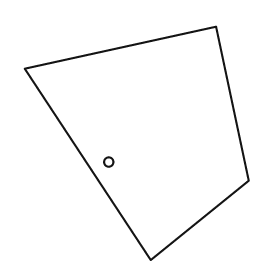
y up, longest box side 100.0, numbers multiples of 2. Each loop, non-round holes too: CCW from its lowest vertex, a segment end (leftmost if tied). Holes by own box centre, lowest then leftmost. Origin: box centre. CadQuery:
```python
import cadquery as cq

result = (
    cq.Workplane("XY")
    .moveTo(6.0, -50.0)
    .lineTo(48.0, -16.0)
    .lineTo(34.0, 50.0)
    .lineTo(-48.0, 32.0)
    .close()
    .moveTo(-12.0, -8.0)
    .circle(2.0)
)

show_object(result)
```